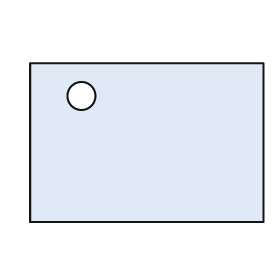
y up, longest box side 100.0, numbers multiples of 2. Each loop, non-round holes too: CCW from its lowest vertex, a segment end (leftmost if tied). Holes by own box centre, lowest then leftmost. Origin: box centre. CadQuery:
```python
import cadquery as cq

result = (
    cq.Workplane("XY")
    .moveTo(-50.0, -34.0)
    .lineTo(50.0, -34.0)
    .lineTo(50.0, 34.0)
    .lineTo(-50.0, 34.0)
    .close()
    .moveTo(-28.0, 20.0)
    .circle(6.0)
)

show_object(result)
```